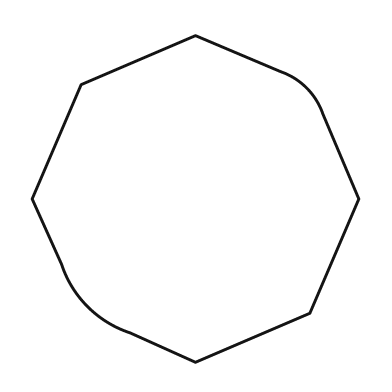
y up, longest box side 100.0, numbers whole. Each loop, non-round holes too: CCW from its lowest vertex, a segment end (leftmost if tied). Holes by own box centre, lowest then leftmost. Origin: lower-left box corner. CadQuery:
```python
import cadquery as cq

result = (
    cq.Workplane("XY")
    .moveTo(50.0, 0.0)
    .lineTo(85.0, 15.0)
    .lineTo(100.0, 50.0)
    .lineTo(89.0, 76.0)
    .threePointArc((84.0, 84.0), (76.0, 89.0))
    .lineTo(50.0, 100.0)
    .lineTo(15.0, 85.0)
    .lineTo(0.0, 50.0)
    .lineTo(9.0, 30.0)
    .threePointArc((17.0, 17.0), (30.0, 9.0))
    .close()
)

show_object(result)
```